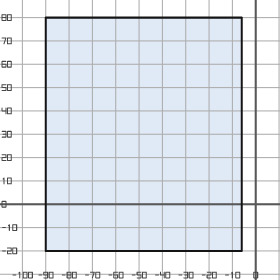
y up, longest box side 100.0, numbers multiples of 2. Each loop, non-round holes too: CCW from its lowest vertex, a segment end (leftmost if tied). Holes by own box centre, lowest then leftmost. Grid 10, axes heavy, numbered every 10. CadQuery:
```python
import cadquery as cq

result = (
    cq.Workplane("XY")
    .moveTo(-90.0, -20.0)
    .lineTo(-6.0, -20.0)
    .lineTo(-6.0, 80.0)
    .lineTo(-90.0, 80.0)
    .close()
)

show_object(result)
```